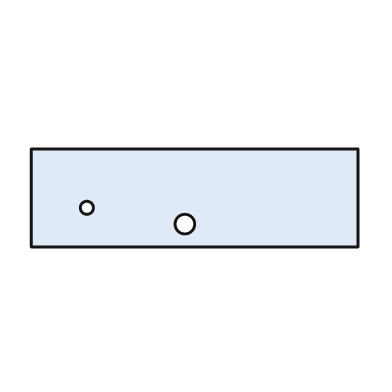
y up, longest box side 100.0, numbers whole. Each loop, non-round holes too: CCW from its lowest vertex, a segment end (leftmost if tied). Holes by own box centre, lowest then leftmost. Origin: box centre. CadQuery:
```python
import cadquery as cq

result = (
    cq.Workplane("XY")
    .moveTo(-50.0, -15.0)
    .lineTo(50.0, -15.0)
    .lineTo(50.0, 15.0)
    .lineTo(-50.0, 15.0)
    .close()
    .moveTo(-3.0, -8.0)
    .circle(3.0)
    .moveTo(-33.0, -3.0)
    .circle(2.0)
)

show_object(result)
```